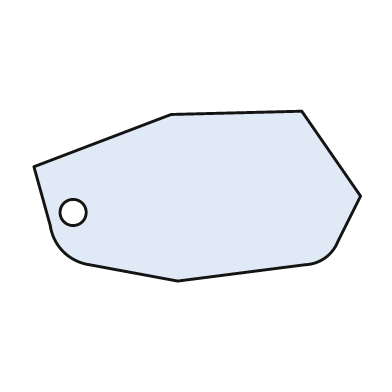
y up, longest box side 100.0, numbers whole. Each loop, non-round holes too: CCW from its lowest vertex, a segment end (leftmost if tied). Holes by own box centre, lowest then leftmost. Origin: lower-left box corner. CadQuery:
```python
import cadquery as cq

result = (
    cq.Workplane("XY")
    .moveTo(44.0, 0.0)
    .lineTo(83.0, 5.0)
    .threePointArc((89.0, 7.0), (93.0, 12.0))
    .lineTo(100.0, 26.0)
    .lineTo(82.0, 52.0)
    .lineTo(42.0, 51.0)
    .lineTo(0.0, 35.0)
    .lineTo(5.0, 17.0)
    .threePointArc((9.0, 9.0), (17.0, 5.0))
    .close()
    .moveTo(12.0, 21.0)
    .circle(4.0)
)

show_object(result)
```